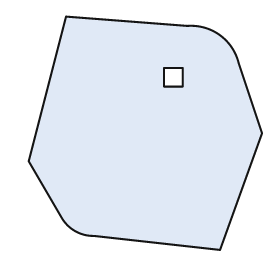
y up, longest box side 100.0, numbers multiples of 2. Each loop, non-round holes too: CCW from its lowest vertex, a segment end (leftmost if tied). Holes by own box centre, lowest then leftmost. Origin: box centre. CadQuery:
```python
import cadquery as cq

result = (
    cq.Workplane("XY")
    .moveTo(32.0, -50.0)
    .lineTo(50.0, 0.0)
    .lineTo(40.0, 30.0)
    .threePointArc((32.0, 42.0), (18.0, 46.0))
    .lineTo(-34.0, 50.0)
    .lineTo(-50.0, -12.0)
    .lineTo(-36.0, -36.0)
    .threePointArc((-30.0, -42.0), (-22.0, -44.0))
    .close()
    .moveTo(8.0, 20.0)
    .lineTo(16.0, 20.0)
    .lineTo(16.0, 28.0)
    .lineTo(8.0, 28.0)
    .close()
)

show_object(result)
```